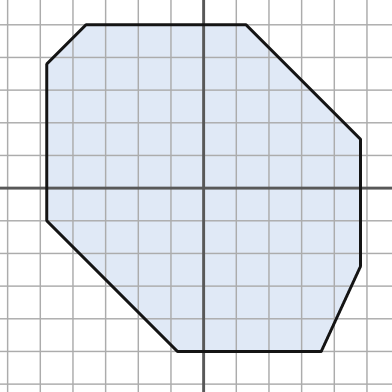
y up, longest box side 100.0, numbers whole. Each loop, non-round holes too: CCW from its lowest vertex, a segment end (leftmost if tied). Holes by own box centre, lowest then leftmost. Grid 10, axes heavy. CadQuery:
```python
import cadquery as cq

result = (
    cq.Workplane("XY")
    .moveTo(-8.0, -50.0)
    .lineTo(36.0, -50.0)
    .lineTo(48.0, -24.0)
    .lineTo(48.0, 15.0)
    .lineTo(13.0, 50.0)
    .lineTo(-36.0, 50.0)
    .lineTo(-48.0, 38.0)
    .lineTo(-48.0, -10.0)
    .close()
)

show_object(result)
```